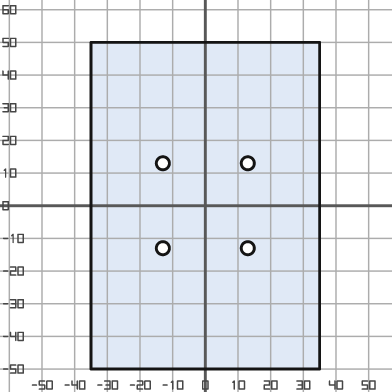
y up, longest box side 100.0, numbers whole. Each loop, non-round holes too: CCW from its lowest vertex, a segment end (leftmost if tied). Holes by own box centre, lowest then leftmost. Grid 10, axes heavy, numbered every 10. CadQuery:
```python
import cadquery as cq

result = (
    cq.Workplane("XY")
    .moveTo(-35.0, -50.0)
    .lineTo(35.0, -50.0)
    .lineTo(35.0, 50.0)
    .lineTo(-35.0, 50.0)
    .close()
    .moveTo(-13.0, -13.0)
    .circle(2.0)
    .moveTo(13.0, -13.0)
    .circle(2.0)
    .moveTo(-13.0, 13.0)
    .circle(2.0)
    .moveTo(13.0, 13.0)
    .circle(2.0)
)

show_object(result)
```